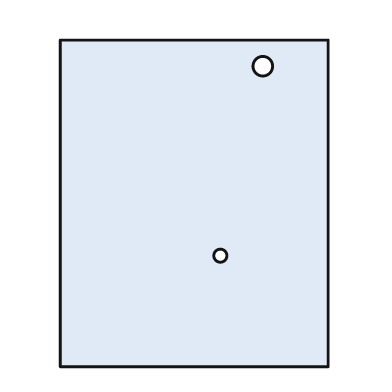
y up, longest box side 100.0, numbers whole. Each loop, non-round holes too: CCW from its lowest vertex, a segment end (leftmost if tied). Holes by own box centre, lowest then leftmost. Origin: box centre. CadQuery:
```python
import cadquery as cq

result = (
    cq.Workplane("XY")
    .moveTo(-41.0, -50.0)
    .lineTo(41.0, -50.0)
    .lineTo(41.0, 50.0)
    .lineTo(-41.0, 50.0)
    .close()
    .moveTo(8.0, -16.0)
    .circle(2.0)
    .moveTo(21.0, 42.0)
    .circle(3.0)
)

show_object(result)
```